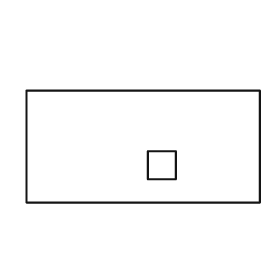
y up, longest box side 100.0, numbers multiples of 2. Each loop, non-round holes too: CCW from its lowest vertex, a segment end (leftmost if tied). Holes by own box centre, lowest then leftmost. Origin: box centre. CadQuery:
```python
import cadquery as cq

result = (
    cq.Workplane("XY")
    .moveTo(-50.0, -24.0)
    .lineTo(50.0, -24.0)
    .lineTo(50.0, 24.0)
    .lineTo(-50.0, 24.0)
    .close()
    .moveTo(2.0, -14.0)
    .lineTo(14.0, -14.0)
    .lineTo(14.0, -2.0)
    .lineTo(2.0, -2.0)
    .close()
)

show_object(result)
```